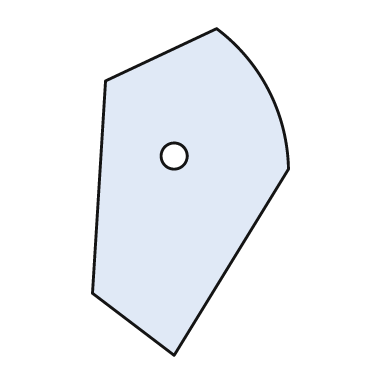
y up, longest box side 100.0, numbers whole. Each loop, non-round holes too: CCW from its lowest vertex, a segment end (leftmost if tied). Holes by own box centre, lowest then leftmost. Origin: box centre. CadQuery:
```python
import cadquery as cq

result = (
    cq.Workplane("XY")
    .moveTo(-5.0, -50.0)
    .lineTo(30.0, 7.0)
    .threePointArc((24.0, 31.0), (8.0, 50.0))
    .lineTo(-26.0, 34.0)
    .lineTo(-30.0, -31.0)
    .close()
    .moveTo(-5.0, 11.0)
    .circle(4.0)
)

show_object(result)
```